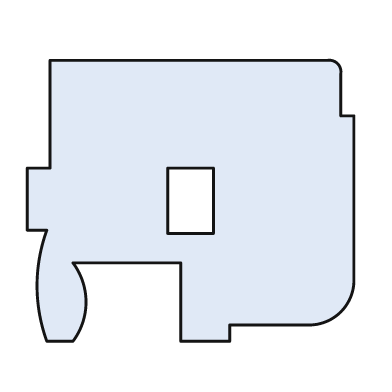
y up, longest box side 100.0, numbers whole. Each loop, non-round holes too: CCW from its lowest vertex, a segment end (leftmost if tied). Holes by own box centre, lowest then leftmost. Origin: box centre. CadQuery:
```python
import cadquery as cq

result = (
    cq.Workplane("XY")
    .moveTo(-44.0, -43.0)
    .lineTo(-36.0, -43.0)
    .threePointArc((-32.0, -31.0), (-36.0, -19.0))
    .lineTo(-3.0, -19.0)
    .lineTo(-3.0, -43.0)
    .lineTo(12.0, -43.0)
    .lineTo(12.0, -38.0)
    .lineTo(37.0, -38.0)
    .threePointArc((46.0, -34.0), (50.0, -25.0))
    .lineTo(50.0, 26.0)
    .lineTo(46.0, 26.0)
    .lineTo(46.0, 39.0)
    .threePointArc((45.0, 42.0), (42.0, 43.0))
    .lineTo(-43.0, 43.0)
    .lineTo(-43.0, 10.0)
    .lineTo(-50.0, 10.0)
    .lineTo(-50.0, -9.0)
    .lineTo(-44.0, -9.0)
    .threePointArc((-47.0, -26.0), (-44.0, -43.0))
    .close()
    .moveTo(-7.0, -10.0)
    .lineTo(7.0, -10.0)
    .lineTo(7.0, 10.0)
    .lineTo(-7.0, 10.0)
    .close()
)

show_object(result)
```